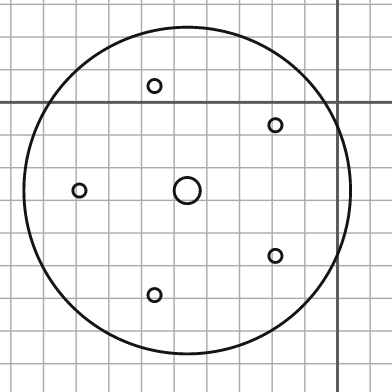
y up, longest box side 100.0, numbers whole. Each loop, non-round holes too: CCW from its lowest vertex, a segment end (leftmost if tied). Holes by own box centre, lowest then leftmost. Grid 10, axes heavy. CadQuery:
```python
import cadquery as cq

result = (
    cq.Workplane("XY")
    .moveTo(-46.0, -27.0)
    .circle(50.0)
    .moveTo(-56.0, -59.0)
    .circle(2.0)
    .moveTo(-19.0, -47.0)
    .circle(2.0)
    .moveTo(-79.0, -27.0)
    .circle(2.0)
    .moveTo(-46.0, -27.0)
    .circle(4.0)
    .moveTo(-19.0, -7.0)
    .circle(2.0)
    .moveTo(-56.0, 5.0)
    .circle(2.0)
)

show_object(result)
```